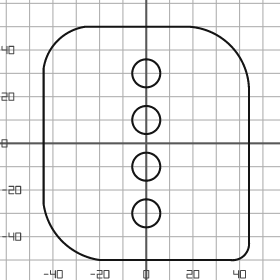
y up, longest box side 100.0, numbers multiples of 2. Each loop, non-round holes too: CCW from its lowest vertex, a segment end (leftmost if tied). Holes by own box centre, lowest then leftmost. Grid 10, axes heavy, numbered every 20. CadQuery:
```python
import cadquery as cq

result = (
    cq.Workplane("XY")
    .moveTo(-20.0, -50.0)
    .lineTo(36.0, -50.0)
    .threePointArc((42.0, -48.0), (44.0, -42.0))
    .lineTo(44.0, 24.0)
    .threePointArc((36.0, 42.0), (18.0, 50.0))
    .lineTo(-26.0, 50.0)
    .threePointArc((-38.0, 44.0), (-44.0, 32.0))
    .lineTo(-44.0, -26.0)
    .threePointArc((-36.0, -42.0), (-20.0, -50.0))
    .close()
    .moveTo(0.0, -30.0)
    .circle(6.0)
    .moveTo(0.0, -10.0)
    .circle(6.0)
    .moveTo(0.0, 10.0)
    .circle(6.0)
    .moveTo(0.0, 30.0)
    .circle(6.0)
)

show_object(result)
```